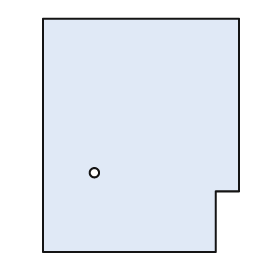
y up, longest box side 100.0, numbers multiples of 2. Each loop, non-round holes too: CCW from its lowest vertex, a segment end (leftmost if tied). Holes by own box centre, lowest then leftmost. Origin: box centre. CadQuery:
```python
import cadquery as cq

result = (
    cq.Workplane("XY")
    .moveTo(-42.0, -50.0)
    .lineTo(32.0, -50.0)
    .lineTo(32.0, -24.0)
    .lineTo(42.0, -24.0)
    .lineTo(42.0, 50.0)
    .lineTo(-42.0, 50.0)
    .close()
    .moveTo(-20.0, -16.0)
    .circle(2.0)
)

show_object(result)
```